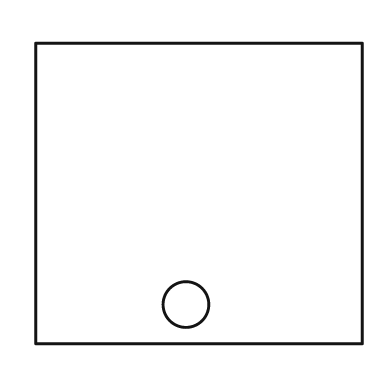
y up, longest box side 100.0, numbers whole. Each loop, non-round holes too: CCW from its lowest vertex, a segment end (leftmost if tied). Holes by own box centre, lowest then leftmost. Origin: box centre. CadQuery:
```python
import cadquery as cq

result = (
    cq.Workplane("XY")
    .moveTo(-50.0, -46.0)
    .lineTo(50.0, -46.0)
    .lineTo(50.0, 46.0)
    .lineTo(-50.0, 46.0)
    .close()
    .moveTo(-4.0, -34.0)
    .circle(7.0)
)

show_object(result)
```